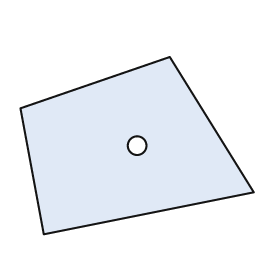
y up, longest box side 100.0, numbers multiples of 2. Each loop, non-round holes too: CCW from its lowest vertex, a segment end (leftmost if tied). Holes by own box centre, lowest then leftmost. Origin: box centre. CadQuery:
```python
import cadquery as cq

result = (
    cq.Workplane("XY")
    .moveTo(-40.0, -38.0)
    .lineTo(50.0, -20.0)
    .lineTo(14.0, 38.0)
    .lineTo(-50.0, 16.0)
    .close()
    .moveTo(0.0, 0.0)
    .circle(4.0)
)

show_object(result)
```